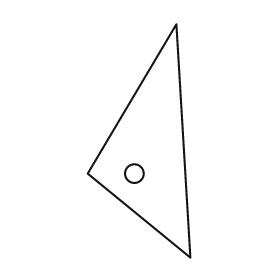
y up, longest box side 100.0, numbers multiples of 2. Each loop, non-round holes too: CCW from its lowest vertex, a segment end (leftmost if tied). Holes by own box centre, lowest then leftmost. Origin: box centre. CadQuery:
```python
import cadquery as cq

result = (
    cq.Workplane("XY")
    .moveTo(22.0, -50.0)
    .lineTo(16.0, 50.0)
    .lineTo(-22.0, -14.0)
    .close()
    .moveTo(-2.0, -14.0)
    .circle(4.0)
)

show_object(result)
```